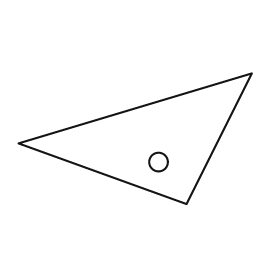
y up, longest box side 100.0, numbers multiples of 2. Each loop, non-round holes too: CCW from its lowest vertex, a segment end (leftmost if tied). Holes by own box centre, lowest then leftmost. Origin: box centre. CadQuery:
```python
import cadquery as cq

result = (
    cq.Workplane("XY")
    .moveTo(22.0, -28.0)
    .lineTo(50.0, 28.0)
    .lineTo(-50.0, -2.0)
    .close()
    .moveTo(10.0, -10.0)
    .circle(4.0)
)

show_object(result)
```